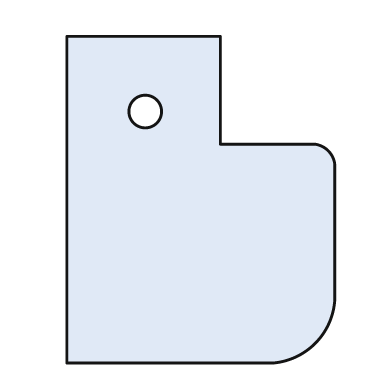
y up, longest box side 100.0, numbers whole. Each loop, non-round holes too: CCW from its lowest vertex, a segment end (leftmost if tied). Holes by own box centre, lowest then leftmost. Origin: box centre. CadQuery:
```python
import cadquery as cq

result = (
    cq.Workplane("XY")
    .moveTo(-41.0, -50.0)
    .lineTo(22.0, -50.0)
    .threePointArc((35.0, -44.0), (41.0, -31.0))
    .lineTo(41.0, 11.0)
    .threePointArc((39.0, 15.0), (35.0, 17.0))
    .lineTo(6.0, 17.0)
    .lineTo(6.0, 50.0)
    .lineTo(-41.0, 50.0)
    .close()
    .moveTo(-17.0, 27.0)
    .circle(5.0)
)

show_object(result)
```